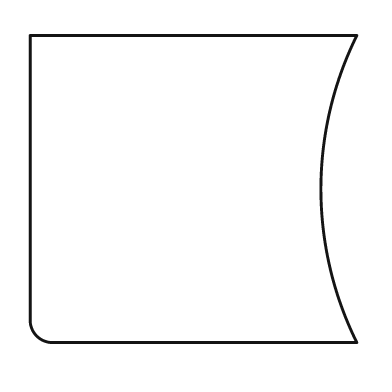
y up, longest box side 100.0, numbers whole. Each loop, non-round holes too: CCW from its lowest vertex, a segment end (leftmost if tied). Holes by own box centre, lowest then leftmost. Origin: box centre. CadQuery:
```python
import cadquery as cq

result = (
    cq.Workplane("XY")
    .moveTo(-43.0, -47.0)
    .lineTo(50.0, -47.0)
    .threePointArc((39.0, 0.0), (50.0, 47.0))
    .lineTo(-50.0, 47.0)
    .lineTo(-50.0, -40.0)
    .threePointArc((-48.0, -45.0), (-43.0, -47.0))
    .close()
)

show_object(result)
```